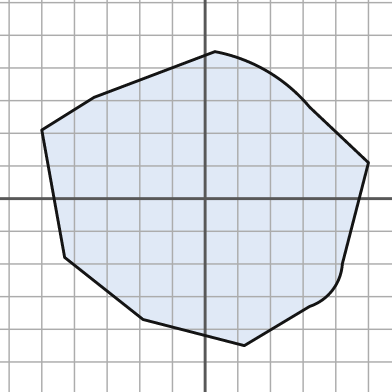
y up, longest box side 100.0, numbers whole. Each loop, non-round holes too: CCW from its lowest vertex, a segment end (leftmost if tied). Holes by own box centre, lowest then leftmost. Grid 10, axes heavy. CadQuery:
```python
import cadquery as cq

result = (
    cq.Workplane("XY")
    .moveTo(12.0, -45.0)
    .lineTo(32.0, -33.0)
    .threePointArc((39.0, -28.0), (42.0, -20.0))
    .lineTo(50.0, 11.0)
    .lineTo(32.0, 28.0)
    .threePointArc((19.0, 39.0), (3.0, 45.0))
    .lineTo(-34.0, 31.0)
    .lineTo(-50.0, 21.0)
    .lineTo(-43.0, -18.0)
    .lineTo(-19.0, -37.0)
    .close()
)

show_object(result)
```